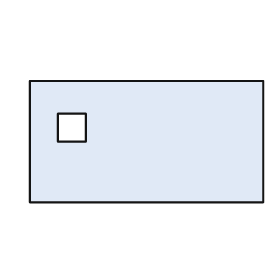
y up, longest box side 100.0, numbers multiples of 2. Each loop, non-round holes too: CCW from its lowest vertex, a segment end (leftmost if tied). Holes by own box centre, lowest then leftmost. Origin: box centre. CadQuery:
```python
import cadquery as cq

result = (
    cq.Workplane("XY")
    .moveTo(-50.0, -26.0)
    .lineTo(50.0, -26.0)
    .lineTo(50.0, 26.0)
    .lineTo(-50.0, 26.0)
    .close()
    .moveTo(-38.0, 0.0)
    .lineTo(-26.0, 0.0)
    .lineTo(-26.0, 12.0)
    .lineTo(-38.0, 12.0)
    .close()
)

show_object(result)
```